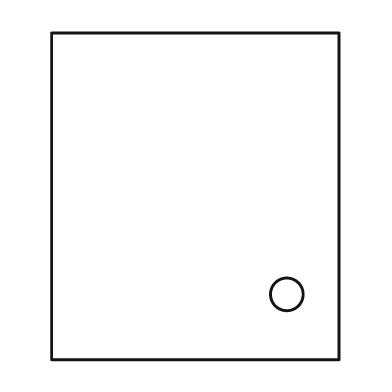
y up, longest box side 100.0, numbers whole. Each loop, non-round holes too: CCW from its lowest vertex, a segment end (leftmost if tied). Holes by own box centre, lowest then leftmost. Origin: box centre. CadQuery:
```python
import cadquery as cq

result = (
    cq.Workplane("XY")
    .moveTo(-44.0, -50.0)
    .lineTo(44.0, -50.0)
    .lineTo(44.0, 50.0)
    .lineTo(-44.0, 50.0)
    .close()
    .moveTo(28.0, -30.0)
    .circle(5.0)
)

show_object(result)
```